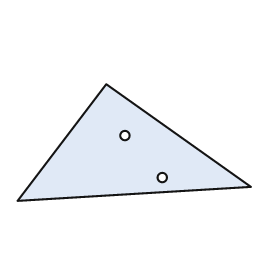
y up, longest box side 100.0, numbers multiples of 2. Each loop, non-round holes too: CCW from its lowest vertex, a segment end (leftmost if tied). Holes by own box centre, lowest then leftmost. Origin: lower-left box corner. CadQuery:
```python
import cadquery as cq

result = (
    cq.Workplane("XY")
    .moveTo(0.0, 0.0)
    .lineTo(100.0, 6.0)
    .lineTo(38.0, 50.0)
    .close()
    .moveTo(62.0, 10.0)
    .circle(2.0)
    .moveTo(46.0, 28.0)
    .circle(2.0)
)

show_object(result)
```